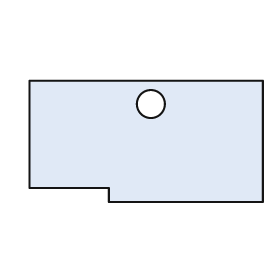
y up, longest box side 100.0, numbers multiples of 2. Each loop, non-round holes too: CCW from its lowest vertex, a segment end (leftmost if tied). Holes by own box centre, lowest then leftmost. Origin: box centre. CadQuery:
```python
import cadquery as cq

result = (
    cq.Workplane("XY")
    .moveTo(-16.0, -26.0)
    .lineTo(50.0, -26.0)
    .lineTo(50.0, 26.0)
    .lineTo(-50.0, 26.0)
    .lineTo(-50.0, -20.0)
    .lineTo(-16.0, -20.0)
    .close()
    .moveTo(2.0, 16.0)
    .circle(6.0)
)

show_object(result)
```